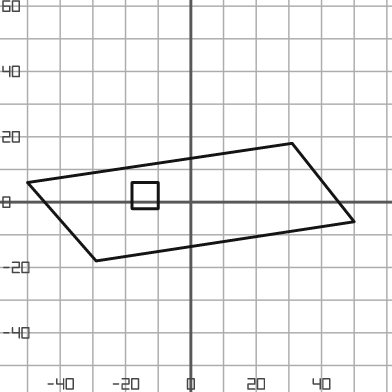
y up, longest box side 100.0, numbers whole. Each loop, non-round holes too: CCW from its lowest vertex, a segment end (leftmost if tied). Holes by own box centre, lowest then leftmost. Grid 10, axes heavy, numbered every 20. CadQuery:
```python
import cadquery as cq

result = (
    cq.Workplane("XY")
    .moveTo(-29.0, -18.0)
    .lineTo(50.0, -6.0)
    .lineTo(31.0, 18.0)
    .lineTo(-50.0, 6.0)
    .close()
    .moveTo(-18.0, -2.0)
    .lineTo(-10.0, -2.0)
    .lineTo(-10.0, 6.0)
    .lineTo(-18.0, 6.0)
    .close()
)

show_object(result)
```